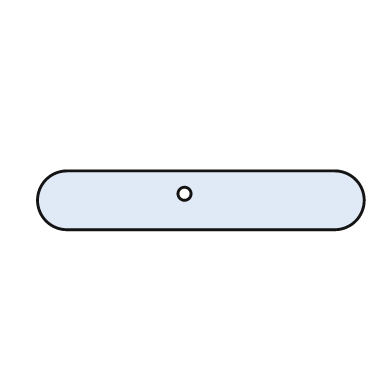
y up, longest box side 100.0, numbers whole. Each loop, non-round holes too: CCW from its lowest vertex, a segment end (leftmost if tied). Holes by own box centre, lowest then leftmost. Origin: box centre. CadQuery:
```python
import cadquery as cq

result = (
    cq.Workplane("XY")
    .moveTo(-41.0, -9.0)
    .lineTo(41.0, -9.0)
    .threePointArc((50.0, 0.0), (41.0, 9.0))
    .lineTo(-41.0, 9.0)
    .threePointArc((-50.0, 0.0), (-41.0, -9.0))
    .close()
    .moveTo(-5.0, 2.0)
    .circle(2.0)
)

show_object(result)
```